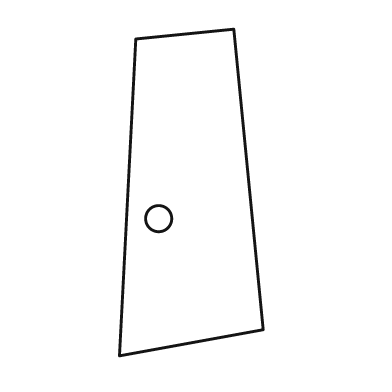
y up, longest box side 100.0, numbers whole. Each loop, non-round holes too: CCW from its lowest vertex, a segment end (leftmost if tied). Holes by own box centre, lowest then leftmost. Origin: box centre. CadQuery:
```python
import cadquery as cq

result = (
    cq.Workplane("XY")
    .moveTo(-22.0, -50.0)
    .lineTo(22.0, -42.0)
    .lineTo(13.0, 50.0)
    .lineTo(-17.0, 47.0)
    .close()
    .moveTo(-10.0, -8.0)
    .circle(4.0)
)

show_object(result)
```